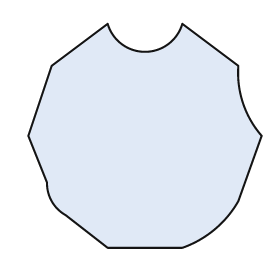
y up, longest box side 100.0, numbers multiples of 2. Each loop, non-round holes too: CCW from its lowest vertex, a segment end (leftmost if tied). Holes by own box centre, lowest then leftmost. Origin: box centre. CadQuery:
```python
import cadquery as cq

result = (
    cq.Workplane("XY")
    .moveTo(-16.0, -48.0)
    .lineTo(16.0, -48.0)
    .threePointArc((30.0, -40.0), (40.0, -28.0))
    .lineTo(50.0, 0.0)
    .threePointArc((42.0, 14.0), (40.0, 30.0))
    .lineTo(16.0, 48.0)
    .threePointArc((0.0, 36.0), (-16.0, 48.0))
    .lineTo(-40.0, 30.0)
    .lineTo(-50.0, 0.0)
    .lineTo(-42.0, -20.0)
    .threePointArc((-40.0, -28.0), (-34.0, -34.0))
    .close()
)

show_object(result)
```